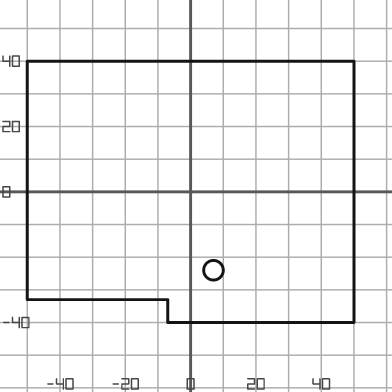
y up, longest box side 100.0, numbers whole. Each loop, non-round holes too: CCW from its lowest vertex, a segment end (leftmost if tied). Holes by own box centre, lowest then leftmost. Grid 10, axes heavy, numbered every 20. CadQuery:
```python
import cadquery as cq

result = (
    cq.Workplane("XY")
    .moveTo(-7.0, -40.0)
    .lineTo(50.0, -40.0)
    .lineTo(50.0, 40.0)
    .lineTo(-50.0, 40.0)
    .lineTo(-50.0, -33.0)
    .lineTo(-7.0, -33.0)
    .close()
    .moveTo(7.0, -24.0)
    .circle(3.0)
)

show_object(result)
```